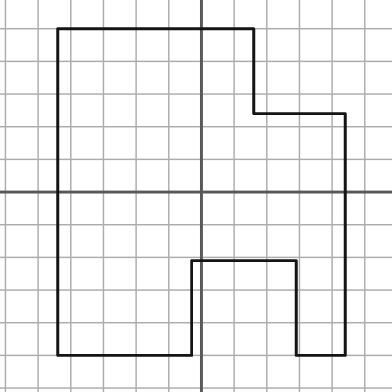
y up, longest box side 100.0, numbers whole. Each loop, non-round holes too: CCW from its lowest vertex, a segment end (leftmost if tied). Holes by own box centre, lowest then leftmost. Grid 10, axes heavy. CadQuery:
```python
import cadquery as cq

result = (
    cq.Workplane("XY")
    .moveTo(-44.0, -50.0)
    .lineTo(-3.0, -50.0)
    .lineTo(-3.0, -21.0)
    .lineTo(29.0, -21.0)
    .lineTo(29.0, -50.0)
    .lineTo(44.0, -50.0)
    .lineTo(44.0, 24.0)
    .lineTo(16.0, 24.0)
    .lineTo(16.0, 50.0)
    .lineTo(-44.0, 50.0)
    .close()
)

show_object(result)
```